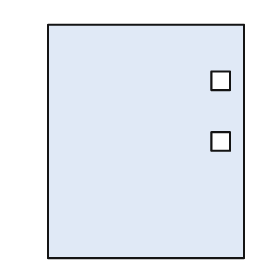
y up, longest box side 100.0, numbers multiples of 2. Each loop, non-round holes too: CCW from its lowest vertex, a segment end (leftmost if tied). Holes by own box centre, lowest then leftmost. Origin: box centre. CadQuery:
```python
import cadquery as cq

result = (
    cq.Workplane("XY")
    .moveTo(-42.0, -50.0)
    .lineTo(42.0, -50.0)
    .lineTo(42.0, 50.0)
    .lineTo(-42.0, 50.0)
    .close()
    .moveTo(28.0, -4.0)
    .lineTo(36.0, -4.0)
    .lineTo(36.0, 4.0)
    .lineTo(28.0, 4.0)
    .close()
    .moveTo(28.0, 22.0)
    .lineTo(36.0, 22.0)
    .lineTo(36.0, 30.0)
    .lineTo(28.0, 30.0)
    .close()
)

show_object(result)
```